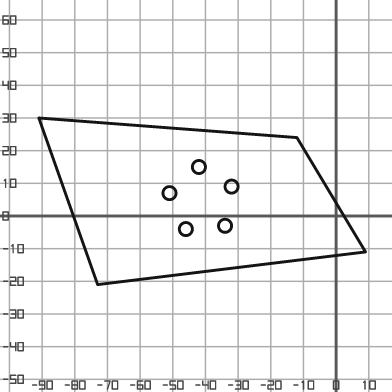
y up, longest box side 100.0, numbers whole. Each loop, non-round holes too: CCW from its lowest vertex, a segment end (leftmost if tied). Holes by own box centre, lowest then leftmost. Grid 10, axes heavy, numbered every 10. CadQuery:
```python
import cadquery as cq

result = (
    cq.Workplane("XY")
    .moveTo(-73.0, -21.0)
    .lineTo(9.0, -11.0)
    .lineTo(-12.0, 24.0)
    .lineTo(-91.0, 30.0)
    .close()
    .moveTo(-46.0, -4.0)
    .circle(2.0)
    .moveTo(-34.0, -3.0)
    .circle(2.0)
    .moveTo(-51.0, 7.0)
    .circle(2.0)
    .moveTo(-32.0, 9.0)
    .circle(2.0)
    .moveTo(-42.0, 15.0)
    .circle(2.0)
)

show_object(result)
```